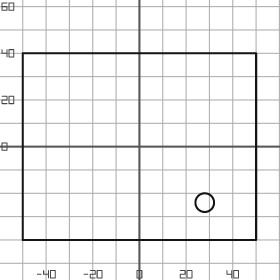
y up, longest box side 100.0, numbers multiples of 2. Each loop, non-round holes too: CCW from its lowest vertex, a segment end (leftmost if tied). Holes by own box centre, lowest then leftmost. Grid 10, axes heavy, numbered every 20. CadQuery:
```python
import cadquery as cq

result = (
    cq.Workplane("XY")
    .moveTo(-50.0, -40.0)
    .lineTo(50.0, -40.0)
    .lineTo(50.0, 40.0)
    .lineTo(-50.0, 40.0)
    .close()
    .moveTo(28.0, -24.0)
    .circle(4.0)
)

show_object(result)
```